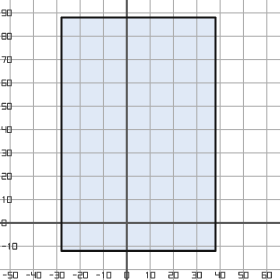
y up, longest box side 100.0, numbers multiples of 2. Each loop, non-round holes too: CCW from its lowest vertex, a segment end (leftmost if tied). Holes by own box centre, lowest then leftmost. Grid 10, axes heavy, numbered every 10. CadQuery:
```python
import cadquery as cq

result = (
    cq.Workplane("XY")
    .moveTo(-28.0, -12.0)
    .lineTo(38.0, -12.0)
    .lineTo(38.0, 88.0)
    .lineTo(-28.0, 88.0)
    .close()
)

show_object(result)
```